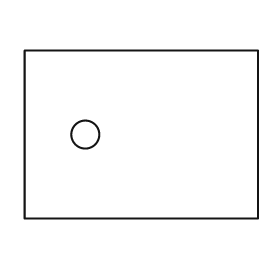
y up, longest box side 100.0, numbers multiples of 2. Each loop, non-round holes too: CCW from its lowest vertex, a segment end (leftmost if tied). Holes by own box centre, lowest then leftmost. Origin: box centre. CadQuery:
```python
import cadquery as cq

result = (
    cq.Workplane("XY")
    .moveTo(-50.0, -36.0)
    .lineTo(50.0, -36.0)
    .lineTo(50.0, 36.0)
    .lineTo(-50.0, 36.0)
    .close()
    .moveTo(-24.0, 0.0)
    .circle(6.0)
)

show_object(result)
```